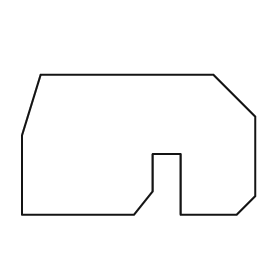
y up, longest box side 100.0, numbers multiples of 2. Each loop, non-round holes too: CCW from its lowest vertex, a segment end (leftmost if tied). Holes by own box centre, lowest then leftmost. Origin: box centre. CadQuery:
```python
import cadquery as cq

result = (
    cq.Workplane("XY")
    .moveTo(-50.0, -30.0)
    .lineTo(-2.0, -30.0)
    .lineTo(6.0, -20.0)
    .lineTo(6.0, -4.0)
    .lineTo(18.0, -4.0)
    .lineTo(18.0, -30.0)
    .lineTo(42.0, -30.0)
    .lineTo(50.0, -22.0)
    .lineTo(50.0, 12.0)
    .lineTo(32.0, 30.0)
    .lineTo(-42.0, 30.0)
    .lineTo(-50.0, 4.0)
    .close()
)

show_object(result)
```